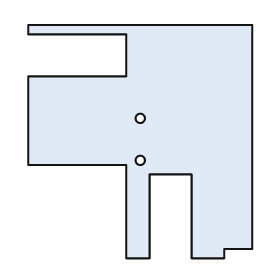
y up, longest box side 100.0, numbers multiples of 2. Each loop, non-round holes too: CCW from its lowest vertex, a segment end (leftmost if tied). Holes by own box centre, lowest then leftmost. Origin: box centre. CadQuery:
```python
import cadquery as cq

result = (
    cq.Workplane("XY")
    .moveTo(-6.0, -50.0)
    .lineTo(4.0, -50.0)
    .lineTo(4.0, -14.0)
    .lineTo(22.0, -14.0)
    .lineTo(22.0, -50.0)
    .lineTo(36.0, -50.0)
    .lineTo(36.0, -46.0)
    .lineTo(48.0, -46.0)
    .lineTo(48.0, 50.0)
    .lineTo(-48.0, 50.0)
    .lineTo(-48.0, 46.0)
    .lineTo(-6.0, 46.0)
    .lineTo(-6.0, 28.0)
    .lineTo(-48.0, 28.0)
    .lineTo(-48.0, -10.0)
    .lineTo(-6.0, -10.0)
    .close()
    .moveTo(0.0, -8.0)
    .circle(2.0)
    .moveTo(0.0, 10.0)
    .circle(2.0)
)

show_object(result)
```